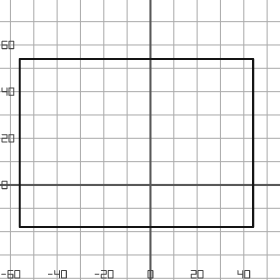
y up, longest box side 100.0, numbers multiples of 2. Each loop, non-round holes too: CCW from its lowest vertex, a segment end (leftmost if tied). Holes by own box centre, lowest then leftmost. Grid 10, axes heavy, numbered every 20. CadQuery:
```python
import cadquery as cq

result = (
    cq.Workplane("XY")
    .moveTo(-56.0, -18.0)
    .lineTo(44.0, -18.0)
    .lineTo(44.0, 54.0)
    .lineTo(-56.0, 54.0)
    .close()
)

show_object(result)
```